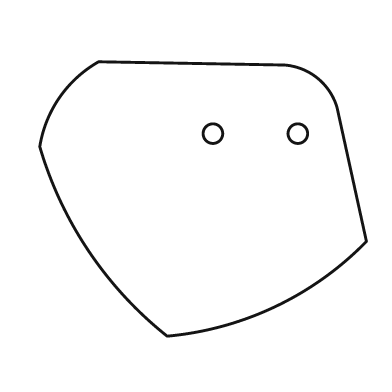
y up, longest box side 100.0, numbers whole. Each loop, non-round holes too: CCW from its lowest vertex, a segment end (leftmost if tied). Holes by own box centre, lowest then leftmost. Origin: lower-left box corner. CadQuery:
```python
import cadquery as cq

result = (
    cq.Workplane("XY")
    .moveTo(39.0, 0.0)
    .threePointArc((72.0, 9.0), (100.0, 29.0))
    .lineTo(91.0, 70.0)
    .threePointArc((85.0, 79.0), (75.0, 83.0))
    .lineTo(18.0, 84.0)
    .threePointArc((6.0, 73.0), (0.0, 58.0))
    .threePointArc((15.0, 26.0), (39.0, 0.0))
    .close()
    .moveTo(53.0, 62.0)
    .circle(3.0)
    .moveTo(79.0, 62.0)
    .circle(3.0)
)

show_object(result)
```